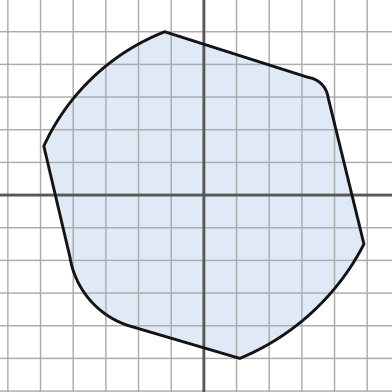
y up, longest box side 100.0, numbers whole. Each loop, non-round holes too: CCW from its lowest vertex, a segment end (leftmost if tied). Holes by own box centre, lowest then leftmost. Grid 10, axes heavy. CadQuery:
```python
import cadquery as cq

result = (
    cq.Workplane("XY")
    .moveTo(11.0, -50.0)
    .threePointArc((33.0, -36.0), (49.0, -15.0))
    .lineTo(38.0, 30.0)
    .threePointArc((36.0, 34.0), (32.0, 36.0))
    .lineTo(-12.0, 50.0)
    .threePointArc((-34.0, 36.0), (-49.0, 15.0))
    .lineTo(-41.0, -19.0)
    .threePointArc((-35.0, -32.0), (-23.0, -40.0))
    .close()
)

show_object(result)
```